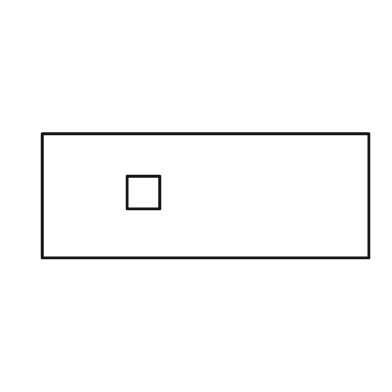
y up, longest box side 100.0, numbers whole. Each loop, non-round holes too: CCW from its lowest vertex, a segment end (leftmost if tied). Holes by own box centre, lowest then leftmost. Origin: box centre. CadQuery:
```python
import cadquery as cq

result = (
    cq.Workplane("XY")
    .moveTo(-50.0, -19.0)
    .lineTo(50.0, -19.0)
    .lineTo(50.0, 19.0)
    .lineTo(-50.0, 19.0)
    .close()
    .moveTo(-24.0, -4.0)
    .lineTo(-14.0, -4.0)
    .lineTo(-14.0, 6.0)
    .lineTo(-24.0, 6.0)
    .close()
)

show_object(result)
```